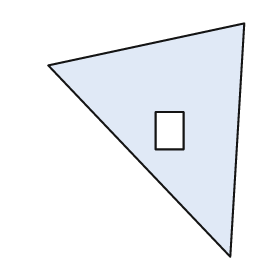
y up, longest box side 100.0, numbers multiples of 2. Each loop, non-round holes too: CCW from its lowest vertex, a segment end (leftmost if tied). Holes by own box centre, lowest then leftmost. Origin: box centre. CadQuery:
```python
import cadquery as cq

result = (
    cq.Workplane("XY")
    .moveTo(36.0, -50.0)
    .lineTo(42.0, 50.0)
    .lineTo(-42.0, 32.0)
    .close()
    .moveTo(4.0, -4.0)
    .lineTo(16.0, -4.0)
    .lineTo(16.0, 12.0)
    .lineTo(4.0, 12.0)
    .close()
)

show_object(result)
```